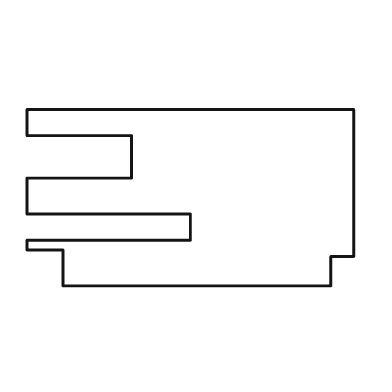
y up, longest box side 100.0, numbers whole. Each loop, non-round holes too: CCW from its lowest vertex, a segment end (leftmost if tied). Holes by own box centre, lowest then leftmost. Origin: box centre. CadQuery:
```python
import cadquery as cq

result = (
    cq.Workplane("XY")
    .moveTo(-39.0, -27.0)
    .lineTo(43.0, -27.0)
    .lineTo(43.0, -18.0)
    .lineTo(50.0, -18.0)
    .lineTo(50.0, 27.0)
    .lineTo(-50.0, 27.0)
    .lineTo(-50.0, 19.0)
    .lineTo(-18.0, 19.0)
    .lineTo(-18.0, 6.0)
    .lineTo(-50.0, 6.0)
    .lineTo(-50.0, -5.0)
    .lineTo(0.0, -5.0)
    .lineTo(0.0, -13.0)
    .lineTo(-50.0, -13.0)
    .lineTo(-50.0, -16.0)
    .lineTo(-39.0, -16.0)
    .close()
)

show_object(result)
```